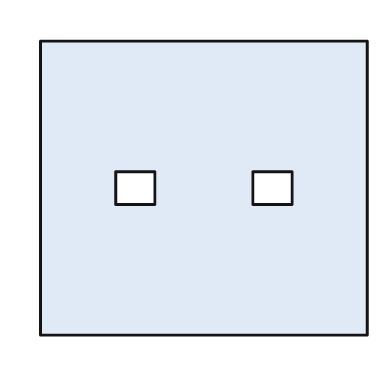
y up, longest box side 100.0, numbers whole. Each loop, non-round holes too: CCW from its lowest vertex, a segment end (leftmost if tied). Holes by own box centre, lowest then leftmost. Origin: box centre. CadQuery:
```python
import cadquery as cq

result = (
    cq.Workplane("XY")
    .moveTo(-50.0, -45.0)
    .lineTo(50.0, -45.0)
    .lineTo(50.0, 45.0)
    .lineTo(-50.0, 45.0)
    .close()
    .moveTo(-27.0, -5.0)
    .lineTo(-15.0, -5.0)
    .lineTo(-15.0, 5.0)
    .lineTo(-27.0, 5.0)
    .close()
    .moveTo(15.0, -5.0)
    .lineTo(27.0, -5.0)
    .lineTo(27.0, 5.0)
    .lineTo(15.0, 5.0)
    .close()
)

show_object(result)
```